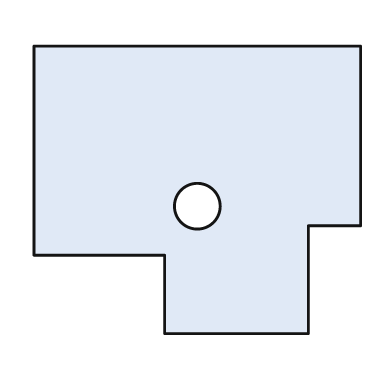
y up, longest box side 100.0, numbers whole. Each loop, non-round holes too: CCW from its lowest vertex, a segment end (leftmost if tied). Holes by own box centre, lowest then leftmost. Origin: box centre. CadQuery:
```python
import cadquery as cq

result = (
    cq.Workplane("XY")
    .moveTo(-10.0, -44.0)
    .lineTo(34.0, -44.0)
    .lineTo(34.0, -11.0)
    .lineTo(50.0, -11.0)
    .lineTo(50.0, 44.0)
    .lineTo(-50.0, 44.0)
    .lineTo(-50.0, -20.0)
    .lineTo(-10.0, -20.0)
    .close()
    .moveTo(0.0, -5.0)
    .circle(7.0)
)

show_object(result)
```